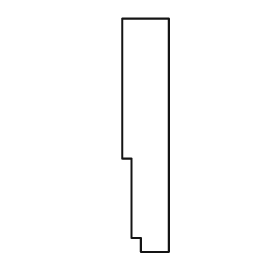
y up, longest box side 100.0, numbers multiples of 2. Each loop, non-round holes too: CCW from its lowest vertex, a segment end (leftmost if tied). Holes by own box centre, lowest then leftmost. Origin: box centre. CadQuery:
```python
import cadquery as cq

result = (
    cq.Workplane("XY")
    .moveTo(-2.0, -50.0)
    .lineTo(10.0, -50.0)
    .lineTo(10.0, 50.0)
    .lineTo(-10.0, 50.0)
    .lineTo(-10.0, -10.0)
    .lineTo(-6.0, -10.0)
    .lineTo(-6.0, -44.0)
    .lineTo(-2.0, -44.0)
    .close()
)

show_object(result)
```